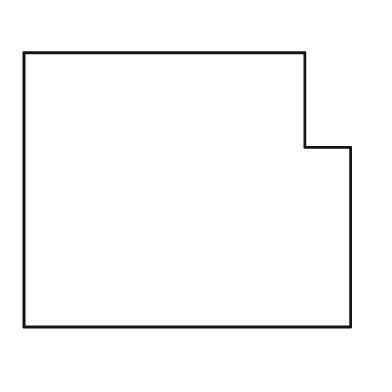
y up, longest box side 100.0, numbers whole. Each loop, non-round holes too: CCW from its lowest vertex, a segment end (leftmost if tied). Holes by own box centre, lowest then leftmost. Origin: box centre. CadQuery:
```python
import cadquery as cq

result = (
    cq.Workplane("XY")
    .moveTo(-50.0, -42.0)
    .lineTo(50.0, -42.0)
    .lineTo(50.0, 13.0)
    .lineTo(36.0, 13.0)
    .lineTo(36.0, 42.0)
    .lineTo(-50.0, 42.0)
    .close()
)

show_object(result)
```